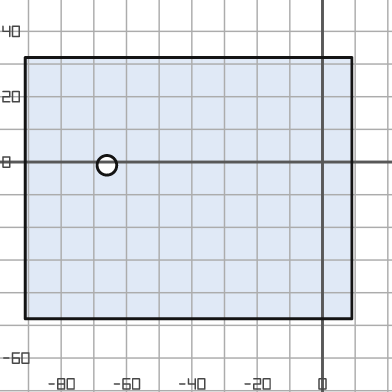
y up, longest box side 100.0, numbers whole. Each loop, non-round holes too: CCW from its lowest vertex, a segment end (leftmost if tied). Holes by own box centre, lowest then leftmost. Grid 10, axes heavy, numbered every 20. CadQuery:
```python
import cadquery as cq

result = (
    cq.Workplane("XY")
    .moveTo(-91.0, -48.0)
    .lineTo(9.0, -48.0)
    .lineTo(9.0, 32.0)
    .lineTo(-91.0, 32.0)
    .close()
    .moveTo(-66.0, -1.0)
    .circle(3.0)
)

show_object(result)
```